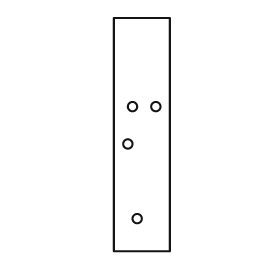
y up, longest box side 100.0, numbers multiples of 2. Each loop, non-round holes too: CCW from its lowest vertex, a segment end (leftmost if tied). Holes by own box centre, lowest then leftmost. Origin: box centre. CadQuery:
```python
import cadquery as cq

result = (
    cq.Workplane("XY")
    .moveTo(-12.0, -50.0)
    .lineTo(12.0, -50.0)
    .lineTo(12.0, 50.0)
    .lineTo(-12.0, 50.0)
    .close()
    .moveTo(-2.0, -36.0)
    .circle(2.0)
    .moveTo(-6.0, -4.0)
    .circle(2.0)
    .moveTo(-4.0, 12.0)
    .circle(2.0)
    .moveTo(6.0, 12.0)
    .circle(2.0)
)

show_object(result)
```